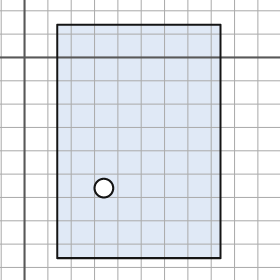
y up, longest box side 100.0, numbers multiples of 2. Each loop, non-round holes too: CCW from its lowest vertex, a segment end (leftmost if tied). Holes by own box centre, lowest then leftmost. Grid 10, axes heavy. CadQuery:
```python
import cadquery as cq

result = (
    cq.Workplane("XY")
    .moveTo(14.0, -86.0)
    .lineTo(84.0, -86.0)
    .lineTo(84.0, 14.0)
    .lineTo(14.0, 14.0)
    .close()
    .moveTo(34.0, -56.0)
    .circle(4.0)
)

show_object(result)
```